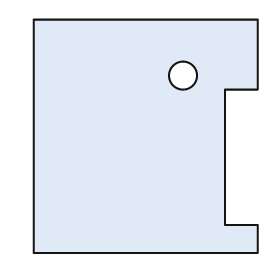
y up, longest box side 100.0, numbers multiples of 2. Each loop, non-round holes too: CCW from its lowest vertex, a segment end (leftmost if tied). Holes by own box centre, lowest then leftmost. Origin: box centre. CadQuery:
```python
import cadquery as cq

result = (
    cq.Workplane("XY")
    .moveTo(-48.0, -50.0)
    .lineTo(48.0, -50.0)
    .lineTo(48.0, -38.0)
    .lineTo(34.0, -38.0)
    .lineTo(34.0, 20.0)
    .lineTo(48.0, 20.0)
    .lineTo(48.0, 50.0)
    .lineTo(-48.0, 50.0)
    .close()
    .moveTo(16.0, 26.0)
    .circle(6.0)
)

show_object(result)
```